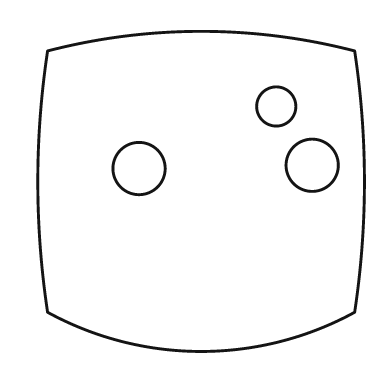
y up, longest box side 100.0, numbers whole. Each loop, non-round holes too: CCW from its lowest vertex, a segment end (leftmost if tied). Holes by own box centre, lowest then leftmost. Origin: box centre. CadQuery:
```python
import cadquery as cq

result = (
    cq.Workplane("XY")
    .moveTo(-47.0, -37.0)
    .threePointArc((0.0, -49.0), (47.0, -37.0))
    .threePointArc((50.0, 3.0), (47.0, 43.0))
    .threePointArc((0.0, 49.0), (-47.0, 43.0))
    .threePointArc((-50.0, 3.0), (-47.0, -37.0))
    .close()
    .moveTo(-19.0, 7.0)
    .circle(8.0)
    .moveTo(34.0, 8.0)
    .circle(8.0)
    .moveTo(23.0, 26.0)
    .circle(6.0)
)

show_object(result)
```